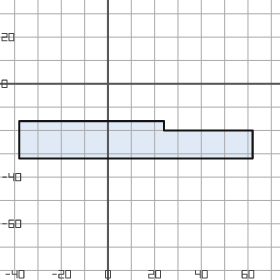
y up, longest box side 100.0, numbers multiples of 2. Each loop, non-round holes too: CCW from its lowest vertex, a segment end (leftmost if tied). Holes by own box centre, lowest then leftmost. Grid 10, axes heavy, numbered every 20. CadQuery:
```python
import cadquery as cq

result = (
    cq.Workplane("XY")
    .moveTo(-38.0, -32.0)
    .lineTo(62.0, -32.0)
    .lineTo(62.0, -20.0)
    .lineTo(24.0, -20.0)
    .lineTo(24.0, -16.0)
    .lineTo(-38.0, -16.0)
    .close()
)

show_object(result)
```